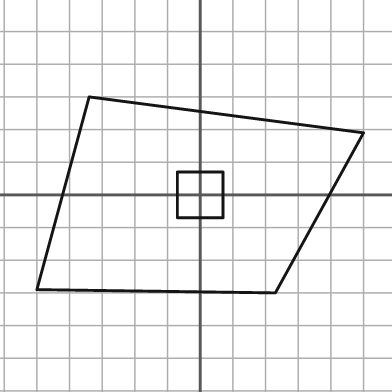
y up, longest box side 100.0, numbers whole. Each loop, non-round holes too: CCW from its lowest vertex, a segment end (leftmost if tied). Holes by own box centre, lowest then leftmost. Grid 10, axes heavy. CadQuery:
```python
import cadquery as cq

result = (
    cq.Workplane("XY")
    .moveTo(23.0, -30.0)
    .lineTo(50.0, 19.0)
    .lineTo(-34.0, 30.0)
    .lineTo(-50.0, -29.0)
    .close()
    .moveTo(-7.0, -7.0)
    .lineTo(7.0, -7.0)
    .lineTo(7.0, 7.0)
    .lineTo(-7.0, 7.0)
    .close()
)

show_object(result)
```